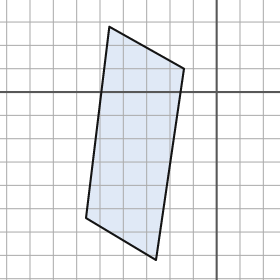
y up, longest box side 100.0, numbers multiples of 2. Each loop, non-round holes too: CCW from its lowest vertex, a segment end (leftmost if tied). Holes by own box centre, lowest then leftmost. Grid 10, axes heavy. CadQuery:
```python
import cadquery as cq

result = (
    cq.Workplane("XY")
    .moveTo(-26.0, -72.0)
    .lineTo(-14.0, 10.0)
    .lineTo(-46.0, 28.0)
    .lineTo(-56.0, -54.0)
    .close()
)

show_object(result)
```